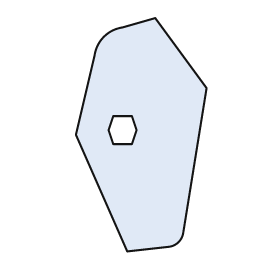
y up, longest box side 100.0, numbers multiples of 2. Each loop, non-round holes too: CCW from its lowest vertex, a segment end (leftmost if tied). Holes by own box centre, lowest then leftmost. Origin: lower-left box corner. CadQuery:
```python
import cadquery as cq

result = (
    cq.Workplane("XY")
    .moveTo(22.0, 0.0)
    .lineTo(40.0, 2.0)
    .threePointArc((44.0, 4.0), (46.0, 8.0))
    .lineTo(56.0, 70.0)
    .lineTo(34.0, 100.0)
    .lineTo(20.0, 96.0)
    .threePointArc((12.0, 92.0), (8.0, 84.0))
    .lineTo(0.0, 50.0)
    .close()
    .moveTo(16.0, 46.0)
    .lineTo(24.0, 46.0)
    .lineTo(26.0, 52.0)
    .lineTo(24.0, 58.0)
    .lineTo(16.0, 58.0)
    .lineTo(14.0, 52.0)
    .close()
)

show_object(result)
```